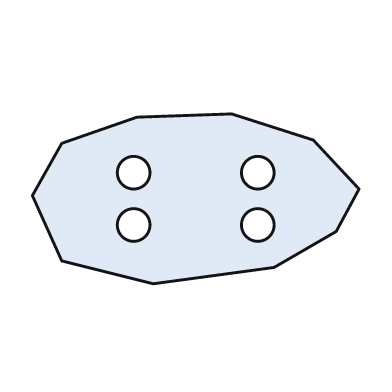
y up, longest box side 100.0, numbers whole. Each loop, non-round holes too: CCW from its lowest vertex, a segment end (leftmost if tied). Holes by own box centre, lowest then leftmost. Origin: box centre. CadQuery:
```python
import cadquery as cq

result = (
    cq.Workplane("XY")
    .moveTo(-13.0, -26.0)
    .lineTo(24.0, -21.0)
    .lineTo(43.0, -10.0)
    .lineTo(50.0, 3.0)
    .lineTo(36.0, 18.0)
    .lineTo(11.0, 26.0)
    .lineTo(-18.0, 25.0)
    .lineTo(-41.0, 17.0)
    .lineTo(-50.0, 1.0)
    .lineTo(-41.0, -19.0)
    .close()
    .moveTo(-19.0, -8.0)
    .circle(5.0)
    .moveTo(19.0, -8.0)
    .circle(5.0)
    .moveTo(-19.0, 8.0)
    .circle(5.0)
    .moveTo(19.0, 8.0)
    .circle(5.0)
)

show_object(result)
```